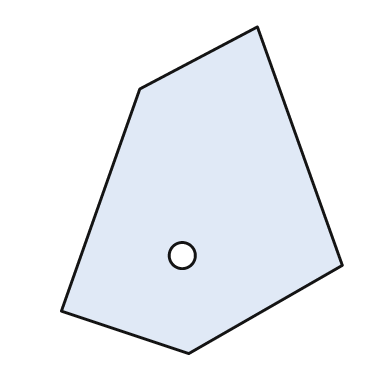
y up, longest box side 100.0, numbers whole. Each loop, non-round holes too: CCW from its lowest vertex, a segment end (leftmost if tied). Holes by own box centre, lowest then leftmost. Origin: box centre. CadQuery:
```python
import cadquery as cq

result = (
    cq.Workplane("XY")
    .moveTo(-4.0, -50.0)
    .lineTo(43.0, -23.0)
    .lineTo(17.0, 50.0)
    .lineTo(-19.0, 31.0)
    .lineTo(-43.0, -37.0)
    .close()
    .moveTo(-6.0, -20.0)
    .circle(4.0)
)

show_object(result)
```